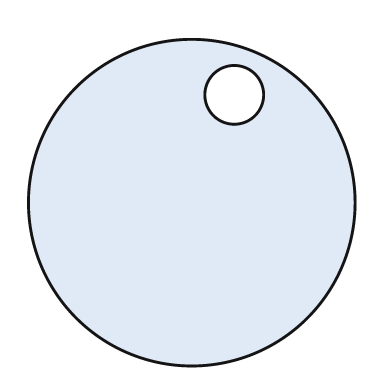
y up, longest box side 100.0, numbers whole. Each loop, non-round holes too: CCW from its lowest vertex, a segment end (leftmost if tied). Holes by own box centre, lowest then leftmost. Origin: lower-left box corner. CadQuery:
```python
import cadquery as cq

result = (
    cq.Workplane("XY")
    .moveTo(50.0, 50.0)
    .circle(50.0)
    .moveTo(63.0, 83.0)
    .circle(9.0)
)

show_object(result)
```